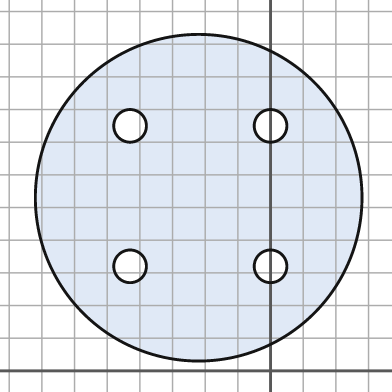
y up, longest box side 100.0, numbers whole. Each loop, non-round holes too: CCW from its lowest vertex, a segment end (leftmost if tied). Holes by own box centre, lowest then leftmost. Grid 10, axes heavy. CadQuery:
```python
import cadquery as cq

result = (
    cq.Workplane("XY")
    .moveTo(-22.0, 53.0)
    .circle(50.0)
    .moveTo(-43.0, 32.0)
    .circle(5.0)
    .moveTo(0.0, 32.0)
    .circle(5.0)
    .moveTo(-43.0, 75.0)
    .circle(5.0)
    .moveTo(0.0, 75.0)
    .circle(5.0)
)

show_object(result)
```